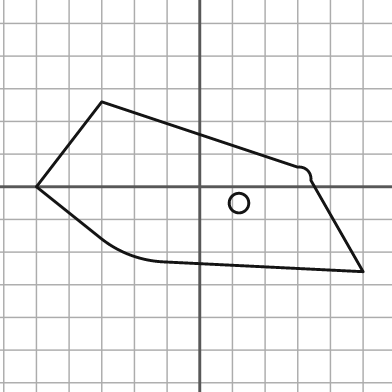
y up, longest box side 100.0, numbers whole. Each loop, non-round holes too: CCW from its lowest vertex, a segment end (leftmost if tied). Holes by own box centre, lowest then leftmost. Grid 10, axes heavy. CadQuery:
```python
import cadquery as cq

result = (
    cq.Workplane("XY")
    .moveTo(50.0, -26.0)
    .lineTo(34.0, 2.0)
    .threePointArc((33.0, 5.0), (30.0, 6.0))
    .lineTo(-30.0, 26.0)
    .lineTo(-50.0, 0.0)
    .lineTo(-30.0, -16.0)
    .threePointArc((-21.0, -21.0), (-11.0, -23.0))
    .close()
    .moveTo(12.0, -5.0)
    .circle(3.0)
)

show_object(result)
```